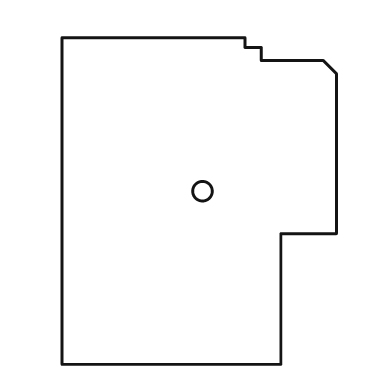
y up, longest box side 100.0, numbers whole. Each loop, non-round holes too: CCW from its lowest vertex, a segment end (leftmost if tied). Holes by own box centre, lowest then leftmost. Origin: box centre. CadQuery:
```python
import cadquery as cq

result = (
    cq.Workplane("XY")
    .moveTo(-42.0, -50.0)
    .lineTo(25.0, -50.0)
    .lineTo(25.0, -10.0)
    .lineTo(42.0, -10.0)
    .lineTo(42.0, 39.0)
    .lineTo(38.0, 43.0)
    .lineTo(19.0, 43.0)
    .lineTo(19.0, 47.0)
    .lineTo(14.0, 47.0)
    .lineTo(14.0, 50.0)
    .lineTo(-42.0, 50.0)
    .close()
    .moveTo(1.0, 3.0)
    .circle(3.0)
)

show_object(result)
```